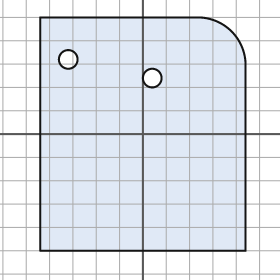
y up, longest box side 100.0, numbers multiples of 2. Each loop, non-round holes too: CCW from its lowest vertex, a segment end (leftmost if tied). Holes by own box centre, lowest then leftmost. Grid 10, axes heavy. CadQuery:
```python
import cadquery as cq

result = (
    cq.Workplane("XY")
    .moveTo(-44.0, -50.0)
    .lineTo(44.0, -50.0)
    .lineTo(44.0, 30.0)
    .threePointArc((38.0, 44.0), (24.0, 50.0))
    .lineTo(-44.0, 50.0)
    .close()
    .moveTo(4.0, 24.0)
    .circle(4.0)
    .moveTo(-32.0, 32.0)
    .circle(4.0)
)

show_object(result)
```